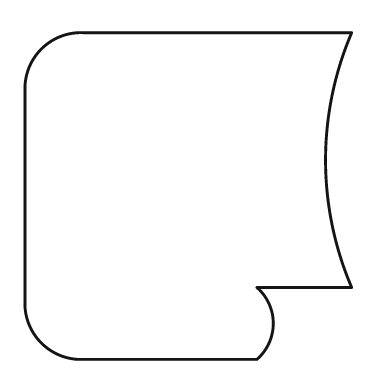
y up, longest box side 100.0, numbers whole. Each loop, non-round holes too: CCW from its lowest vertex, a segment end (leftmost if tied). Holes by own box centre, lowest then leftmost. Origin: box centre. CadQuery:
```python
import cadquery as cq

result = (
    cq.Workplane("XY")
    .moveTo(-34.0, -50.0)
    .lineTo(21.0, -50.0)
    .threePointArc((26.0, -39.0), (21.0, -28.0))
    .lineTo(50.0, -28.0)
    .threePointArc((42.0, 11.0), (50.0, 50.0))
    .lineTo(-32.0, 50.0)
    .threePointArc((-45.0, 45.0), (-50.0, 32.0))
    .lineTo(-50.0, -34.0)
    .threePointArc((-45.0, -45.0), (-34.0, -50.0))
    .close()
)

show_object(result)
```